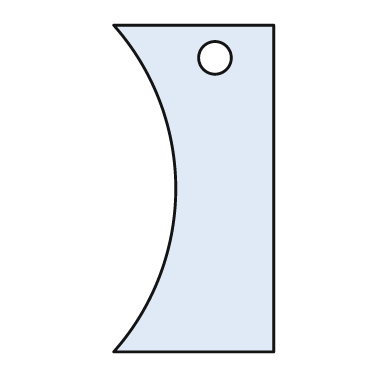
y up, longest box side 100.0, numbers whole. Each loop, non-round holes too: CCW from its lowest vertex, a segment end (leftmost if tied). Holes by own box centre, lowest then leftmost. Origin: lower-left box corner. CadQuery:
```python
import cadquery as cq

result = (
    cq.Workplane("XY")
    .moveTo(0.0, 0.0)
    .lineTo(49.0, 0.0)
    .lineTo(49.0, 100.0)
    .lineTo(0.0, 100.0)
    .threePointArc((19.0, 50.0), (0.0, 0.0))
    .close()
    .moveTo(31.0, 90.0)
    .circle(5.0)
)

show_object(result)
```